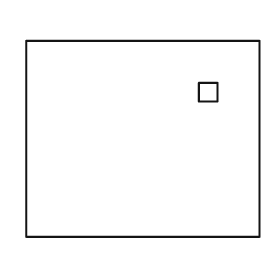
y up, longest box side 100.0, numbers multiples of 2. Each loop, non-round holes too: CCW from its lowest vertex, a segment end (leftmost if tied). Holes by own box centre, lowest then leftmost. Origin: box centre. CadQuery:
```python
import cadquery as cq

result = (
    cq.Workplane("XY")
    .moveTo(-50.0, -42.0)
    .lineTo(50.0, -42.0)
    .lineTo(50.0, 42.0)
    .lineTo(-50.0, 42.0)
    .close()
    .moveTo(24.0, 16.0)
    .lineTo(32.0, 16.0)
    .lineTo(32.0, 24.0)
    .lineTo(24.0, 24.0)
    .close()
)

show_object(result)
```